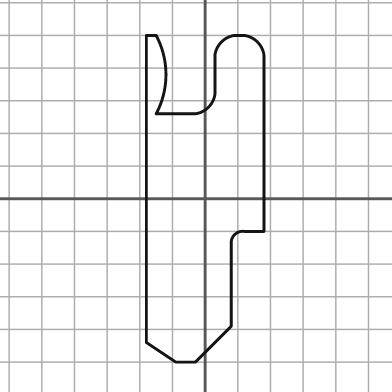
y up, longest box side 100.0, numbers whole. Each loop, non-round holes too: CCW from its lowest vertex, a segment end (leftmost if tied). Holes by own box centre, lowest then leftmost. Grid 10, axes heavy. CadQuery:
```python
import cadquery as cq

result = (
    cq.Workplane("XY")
    .moveTo(-9.0, -50.0)
    .lineTo(-3.0, -50.0)
    .lineTo(8.0, -39.0)
    .lineTo(8.0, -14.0)
    .threePointArc((9.0, -11.0), (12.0, -10.0))
    .lineTo(18.0, -10.0)
    .lineTo(18.0, 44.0)
    .threePointArc((16.0, 48.0), (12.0, 50.0))
    .lineTo(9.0, 50.0)
    .threePointArc((5.0, 48.0), (3.0, 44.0))
    .lineTo(3.0, 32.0)
    .threePointArc((1.0, 28.0), (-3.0, 26.0))
    .lineTo(-15.0, 26.0)
    .threePointArc((-12.0, 38.0), (-15.0, 50.0))
    .lineTo(-18.0, 50.0)
    .lineTo(-18.0, -44.0)
    .close()
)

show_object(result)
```